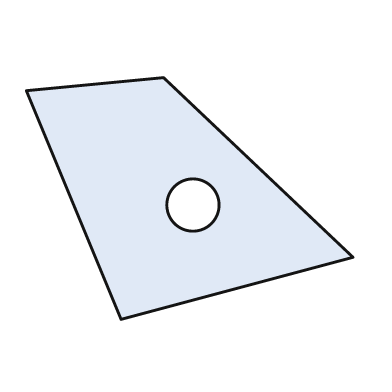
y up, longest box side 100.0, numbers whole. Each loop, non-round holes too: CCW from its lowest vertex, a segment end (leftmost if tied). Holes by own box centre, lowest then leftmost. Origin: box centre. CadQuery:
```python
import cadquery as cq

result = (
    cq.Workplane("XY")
    .moveTo(-21.0, -37.0)
    .lineTo(50.0, -18.0)
    .lineTo(-8.0, 37.0)
    .lineTo(-50.0, 33.0)
    .close()
    .moveTo(1.0, -2.0)
    .circle(8.0)
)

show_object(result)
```